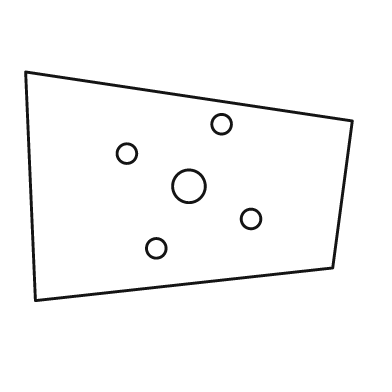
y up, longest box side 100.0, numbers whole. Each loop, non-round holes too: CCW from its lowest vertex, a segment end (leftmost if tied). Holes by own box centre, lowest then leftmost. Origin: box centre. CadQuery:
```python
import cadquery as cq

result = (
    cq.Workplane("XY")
    .moveTo(-47.0, -35.0)
    .lineTo(44.0, -25.0)
    .lineTo(50.0, 20.0)
    .lineTo(-50.0, 35.0)
    .close()
    .moveTo(-10.0, -19.0)
    .circle(3.0)
    .moveTo(19.0, -10.0)
    .circle(3.0)
    .moveTo(0.0, 0.0)
    .circle(5.0)
    .moveTo(-19.0, 10.0)
    .circle(3.0)
    .moveTo(10.0, 19.0)
    .circle(3.0)
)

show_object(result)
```